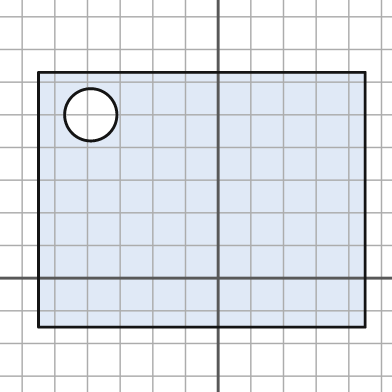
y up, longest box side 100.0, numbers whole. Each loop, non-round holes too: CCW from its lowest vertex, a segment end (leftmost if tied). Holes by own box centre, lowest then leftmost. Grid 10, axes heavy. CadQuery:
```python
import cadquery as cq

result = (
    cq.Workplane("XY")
    .moveTo(-55.0, -15.0)
    .lineTo(45.0, -15.0)
    .lineTo(45.0, 63.0)
    .lineTo(-55.0, 63.0)
    .close()
    .moveTo(-39.0, 50.0)
    .circle(8.0)
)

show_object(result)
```